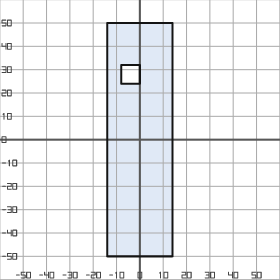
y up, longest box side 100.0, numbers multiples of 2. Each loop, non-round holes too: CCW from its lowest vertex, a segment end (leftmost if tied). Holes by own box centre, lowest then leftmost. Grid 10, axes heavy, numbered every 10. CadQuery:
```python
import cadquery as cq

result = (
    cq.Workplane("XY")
    .moveTo(-14.0, -50.0)
    .lineTo(14.0, -50.0)
    .lineTo(14.0, 50.0)
    .lineTo(-14.0, 50.0)
    .close()
    .moveTo(-8.0, 24.0)
    .lineTo(0.0, 24.0)
    .lineTo(0.0, 32.0)
    .lineTo(-8.0, 32.0)
    .close()
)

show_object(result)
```